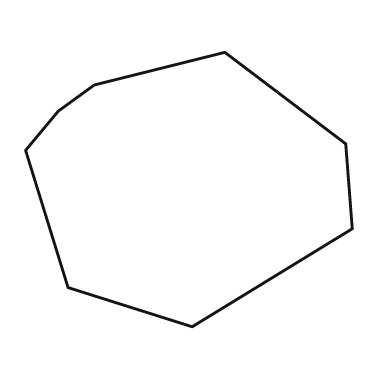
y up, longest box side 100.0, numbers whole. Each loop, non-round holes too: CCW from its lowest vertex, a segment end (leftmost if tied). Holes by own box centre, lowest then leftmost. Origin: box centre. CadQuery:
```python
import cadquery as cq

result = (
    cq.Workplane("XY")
    .moveTo(1.0, -42.0)
    .lineTo(50.0, -12.0)
    .lineTo(48.0, 14.0)
    .lineTo(11.0, 42.0)
    .lineTo(-29.0, 32.0)
    .lineTo(-40.0, 24.0)
    .lineTo(-50.0, 12.0)
    .lineTo(-37.0, -30.0)
    .close()
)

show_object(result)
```